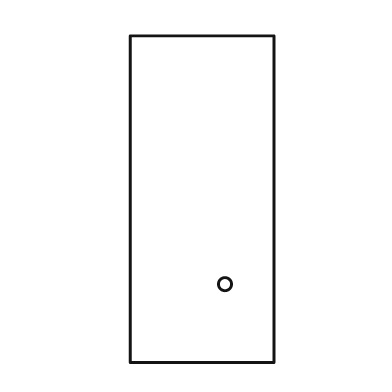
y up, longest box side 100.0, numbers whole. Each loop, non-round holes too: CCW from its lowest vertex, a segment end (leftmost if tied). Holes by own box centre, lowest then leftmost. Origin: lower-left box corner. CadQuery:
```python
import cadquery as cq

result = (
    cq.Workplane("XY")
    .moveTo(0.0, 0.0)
    .lineTo(44.0, 0.0)
    .lineTo(44.0, 100.0)
    .lineTo(0.0, 100.0)
    .close()
    .moveTo(29.0, 24.0)
    .circle(2.0)
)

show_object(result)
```